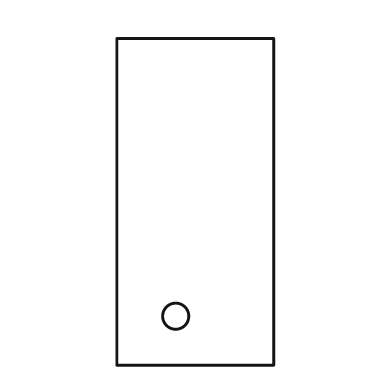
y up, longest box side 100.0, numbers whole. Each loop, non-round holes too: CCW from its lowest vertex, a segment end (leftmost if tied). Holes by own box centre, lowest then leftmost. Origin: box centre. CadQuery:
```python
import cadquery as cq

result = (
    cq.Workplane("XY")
    .moveTo(-24.0, -50.0)
    .lineTo(24.0, -50.0)
    .lineTo(24.0, 50.0)
    .lineTo(-24.0, 50.0)
    .close()
    .moveTo(-6.0, -35.0)
    .circle(4.0)
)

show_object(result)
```